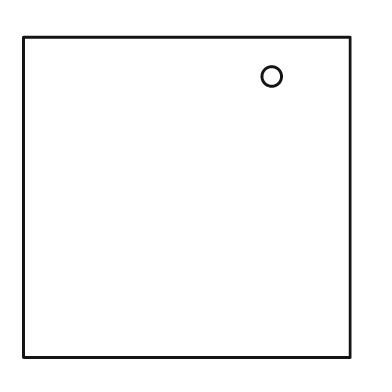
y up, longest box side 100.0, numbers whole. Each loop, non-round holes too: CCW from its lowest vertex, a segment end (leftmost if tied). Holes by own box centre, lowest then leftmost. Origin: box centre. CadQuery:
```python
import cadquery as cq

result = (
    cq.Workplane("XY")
    .moveTo(-50.0, -49.0)
    .lineTo(50.0, -49.0)
    .lineTo(50.0, 49.0)
    .lineTo(-50.0, 49.0)
    .close()
    .moveTo(26.0, 37.0)
    .circle(3.0)
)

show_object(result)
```